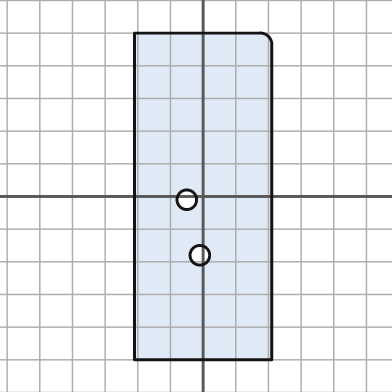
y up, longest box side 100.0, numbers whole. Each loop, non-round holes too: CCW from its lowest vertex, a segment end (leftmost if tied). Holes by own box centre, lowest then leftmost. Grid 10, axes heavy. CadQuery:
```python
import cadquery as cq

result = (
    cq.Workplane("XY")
    .moveTo(-21.0, -50.0)
    .lineTo(21.0, -50.0)
    .lineTo(21.0, 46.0)
    .threePointArc((20.0, 49.0), (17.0, 50.0))
    .lineTo(-21.0, 50.0)
    .close()
    .moveTo(-1.0, -18.0)
    .circle(3.0)
    .moveTo(-5.0, -1.0)
    .circle(3.0)
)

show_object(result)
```